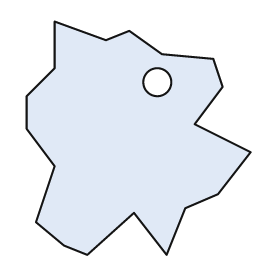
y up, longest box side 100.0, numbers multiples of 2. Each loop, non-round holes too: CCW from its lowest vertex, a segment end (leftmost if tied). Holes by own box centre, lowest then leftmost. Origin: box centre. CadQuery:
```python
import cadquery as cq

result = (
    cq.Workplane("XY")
    .moveTo(-22.0, -50.0)
    .lineTo(-2.0, -32.0)
    .lineTo(12.0, -50.0)
    .lineTo(20.0, -30.0)
    .lineTo(34.0, -24.0)
    .lineTo(48.0, -6.0)
    .lineTo(24.0, 6.0)
    .lineTo(36.0, 22.0)
    .lineTo(32.0, 34.0)
    .lineTo(10.0, 36.0)
    .lineTo(-4.0, 46.0)
    .lineTo(-14.0, 42.0)
    .lineTo(-36.0, 50.0)
    .lineTo(-36.0, 30.0)
    .lineTo(-48.0, 18.0)
    .lineTo(-48.0, 4.0)
    .lineTo(-36.0, -12.0)
    .lineTo(-44.0, -36.0)
    .lineTo(-32.0, -46.0)
    .close()
    .moveTo(8.0, 24.0)
    .circle(6.0)
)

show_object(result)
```